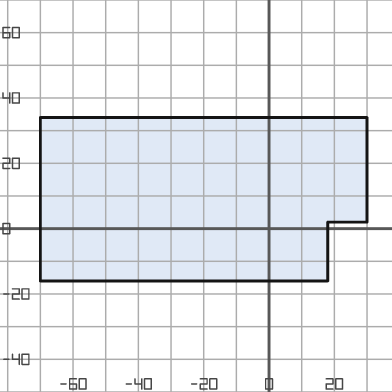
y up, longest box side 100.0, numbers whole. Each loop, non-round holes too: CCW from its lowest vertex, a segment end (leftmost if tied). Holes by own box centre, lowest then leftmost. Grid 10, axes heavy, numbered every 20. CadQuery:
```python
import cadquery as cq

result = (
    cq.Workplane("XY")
    .moveTo(-70.0, -16.0)
    .lineTo(18.0, -16.0)
    .lineTo(18.0, 2.0)
    .lineTo(30.0, 2.0)
    .lineTo(30.0, 34.0)
    .lineTo(-70.0, 34.0)
    .close()
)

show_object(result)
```